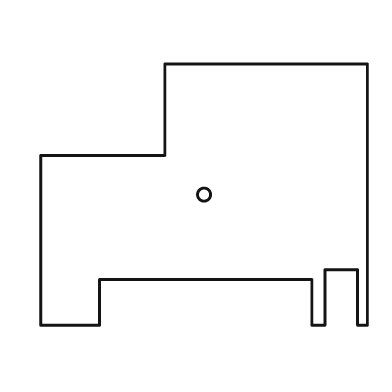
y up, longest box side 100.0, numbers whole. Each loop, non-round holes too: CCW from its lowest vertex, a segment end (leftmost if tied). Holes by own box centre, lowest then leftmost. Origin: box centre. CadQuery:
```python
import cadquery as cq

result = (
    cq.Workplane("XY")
    .moveTo(-50.0, -40.0)
    .lineTo(-32.0, -40.0)
    .lineTo(-32.0, -26.0)
    .lineTo(33.0, -26.0)
    .lineTo(33.0, -40.0)
    .lineTo(37.0, -40.0)
    .lineTo(37.0, -23.0)
    .lineTo(47.0, -23.0)
    .lineTo(47.0, -40.0)
    .lineTo(50.0, -40.0)
    .lineTo(50.0, 40.0)
    .lineTo(-12.0, 40.0)
    .lineTo(-12.0, 12.0)
    .lineTo(-50.0, 12.0)
    .close()
    .moveTo(0.0, 0.0)
    .circle(2.0)
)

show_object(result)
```